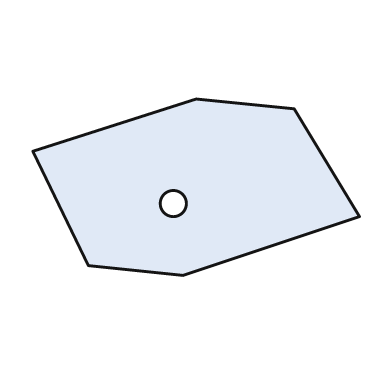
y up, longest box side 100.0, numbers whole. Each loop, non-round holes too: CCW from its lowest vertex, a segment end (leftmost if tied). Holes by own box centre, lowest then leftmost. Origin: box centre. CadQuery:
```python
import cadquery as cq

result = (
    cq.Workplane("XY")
    .moveTo(-4.0, -27.0)
    .lineTo(50.0, -9.0)
    .lineTo(30.0, 24.0)
    .lineTo(0.0, 27.0)
    .lineTo(-50.0, 11.0)
    .lineTo(-33.0, -24.0)
    .close()
    .moveTo(-7.0, -5.0)
    .circle(4.0)
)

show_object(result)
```